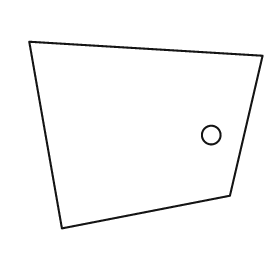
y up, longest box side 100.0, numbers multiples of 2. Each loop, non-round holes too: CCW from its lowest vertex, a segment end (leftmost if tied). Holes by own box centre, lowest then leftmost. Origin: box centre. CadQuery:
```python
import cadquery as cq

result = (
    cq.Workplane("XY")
    .moveTo(-36.0, -40.0)
    .lineTo(36.0, -26.0)
    .lineTo(50.0, 34.0)
    .lineTo(-50.0, 40.0)
    .close()
    .moveTo(28.0, 0.0)
    .circle(4.0)
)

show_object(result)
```